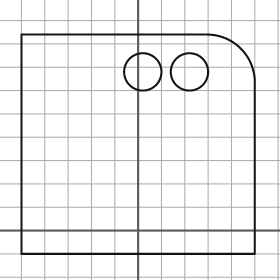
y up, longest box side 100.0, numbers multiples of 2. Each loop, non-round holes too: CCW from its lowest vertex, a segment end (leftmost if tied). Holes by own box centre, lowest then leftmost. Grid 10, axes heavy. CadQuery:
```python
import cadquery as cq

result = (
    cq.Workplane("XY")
    .moveTo(-50.0, -10.0)
    .lineTo(50.0, -10.0)
    .lineTo(50.0, 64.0)
    .threePointArc((44.0, 78.0), (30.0, 84.0))
    .lineTo(-50.0, 84.0)
    .close()
    .moveTo(2.0, 68.0)
    .circle(8.0)
    .moveTo(22.0, 68.0)
    .circle(8.0)
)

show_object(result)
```